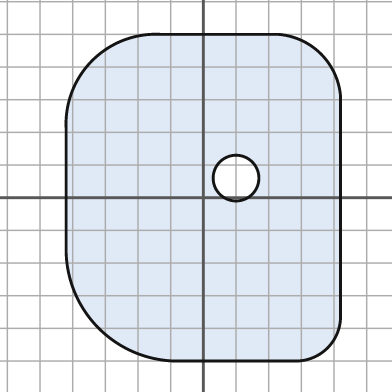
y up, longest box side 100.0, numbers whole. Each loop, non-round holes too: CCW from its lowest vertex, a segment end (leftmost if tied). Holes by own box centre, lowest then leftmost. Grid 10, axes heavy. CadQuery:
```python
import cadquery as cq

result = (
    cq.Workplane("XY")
    .moveTo(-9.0, -50.0)
    .lineTo(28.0, -50.0)
    .threePointArc((38.0, -46.0), (42.0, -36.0))
    .lineTo(42.0, 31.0)
    .threePointArc((36.0, 44.0), (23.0, 50.0))
    .lineTo(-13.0, 50.0)
    .threePointArc((-34.0, 42.0), (-42.0, 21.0))
    .lineTo(-42.0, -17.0)
    .threePointArc((-32.0, -40.0), (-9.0, -50.0))
    .close()
    .moveTo(10.0, 6.0)
    .circle(7.0)
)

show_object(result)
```